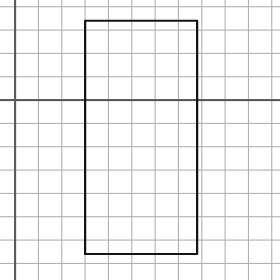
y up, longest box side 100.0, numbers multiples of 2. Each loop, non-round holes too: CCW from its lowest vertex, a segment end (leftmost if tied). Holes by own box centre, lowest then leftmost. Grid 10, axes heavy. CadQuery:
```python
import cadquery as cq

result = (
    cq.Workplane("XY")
    .moveTo(30.0, -66.0)
    .lineTo(78.0, -66.0)
    .lineTo(78.0, 34.0)
    .lineTo(30.0, 34.0)
    .close()
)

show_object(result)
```